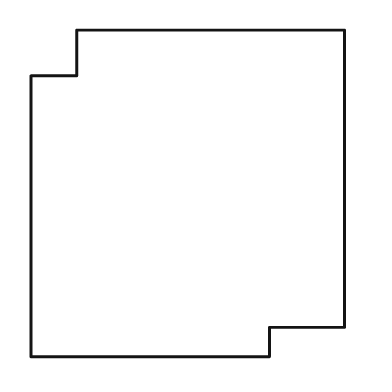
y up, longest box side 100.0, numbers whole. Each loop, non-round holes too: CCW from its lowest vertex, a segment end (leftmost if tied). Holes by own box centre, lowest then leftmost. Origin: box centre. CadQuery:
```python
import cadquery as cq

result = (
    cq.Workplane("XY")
    .moveTo(-48.0, -50.0)
    .lineTo(25.0, -50.0)
    .lineTo(25.0, -41.0)
    .lineTo(48.0, -41.0)
    .lineTo(48.0, 50.0)
    .lineTo(-34.0, 50.0)
    .lineTo(-34.0, 36.0)
    .lineTo(-48.0, 36.0)
    .close()
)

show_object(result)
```